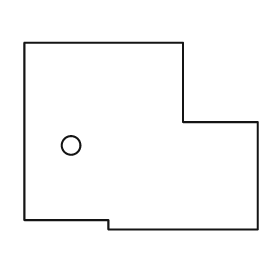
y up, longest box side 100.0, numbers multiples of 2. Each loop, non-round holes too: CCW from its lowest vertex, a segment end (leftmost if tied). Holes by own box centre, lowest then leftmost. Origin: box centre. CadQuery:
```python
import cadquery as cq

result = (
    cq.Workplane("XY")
    .moveTo(-14.0, -40.0)
    .lineTo(50.0, -40.0)
    .lineTo(50.0, 6.0)
    .lineTo(18.0, 6.0)
    .lineTo(18.0, 40.0)
    .lineTo(-50.0, 40.0)
    .lineTo(-50.0, -36.0)
    .lineTo(-14.0, -36.0)
    .close()
    .moveTo(-30.0, -4.0)
    .circle(4.0)
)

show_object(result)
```